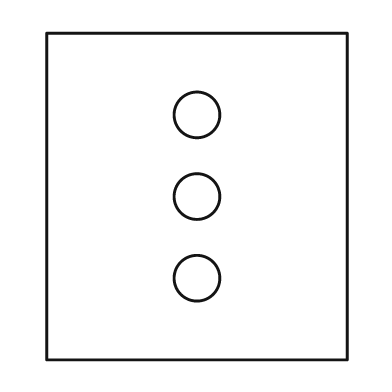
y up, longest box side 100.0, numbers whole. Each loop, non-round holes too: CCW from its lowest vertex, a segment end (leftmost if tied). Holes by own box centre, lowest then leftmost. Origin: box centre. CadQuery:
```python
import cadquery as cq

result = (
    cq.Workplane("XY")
    .moveTo(-46.0, -50.0)
    .lineTo(46.0, -50.0)
    .lineTo(46.0, 50.0)
    .lineTo(-46.0, 50.0)
    .close()
    .moveTo(0.0, -25.0)
    .circle(7.0)
    .moveTo(0.0, 0.0)
    .circle(7.0)
    .moveTo(0.0, 25.0)
    .circle(7.0)
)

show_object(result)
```